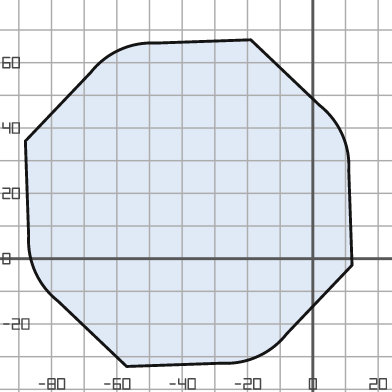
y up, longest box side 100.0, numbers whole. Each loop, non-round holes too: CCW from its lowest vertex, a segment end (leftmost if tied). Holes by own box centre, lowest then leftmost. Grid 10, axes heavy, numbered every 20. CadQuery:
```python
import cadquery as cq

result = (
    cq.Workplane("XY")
    .moveTo(-57.0, -33.0)
    .lineTo(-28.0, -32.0)
    .threePointArc((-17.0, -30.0), (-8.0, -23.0))
    .lineTo(12.0, -2.0)
    .lineTo(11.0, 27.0)
    .threePointArc((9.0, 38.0), (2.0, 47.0))
    .lineTo(-19.0, 67.0)
    .lineTo(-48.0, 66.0)
    .threePointArc((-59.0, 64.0), (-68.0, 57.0))
    .lineTo(-88.0, 36.0)
    .lineTo(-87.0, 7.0)
    .threePointArc((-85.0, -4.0), (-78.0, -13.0))
    .close()
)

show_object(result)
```